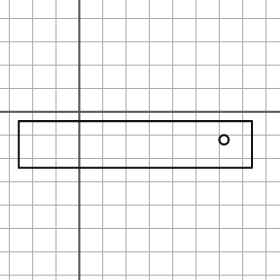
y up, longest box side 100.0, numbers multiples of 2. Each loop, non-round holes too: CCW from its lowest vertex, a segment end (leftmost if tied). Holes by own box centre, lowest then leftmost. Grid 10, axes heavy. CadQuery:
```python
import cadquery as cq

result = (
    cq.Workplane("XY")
    .moveTo(-26.0, -24.0)
    .lineTo(74.0, -24.0)
    .lineTo(74.0, -4.0)
    .lineTo(-26.0, -4.0)
    .close()
    .moveTo(62.0, -12.0)
    .circle(2.0)
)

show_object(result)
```